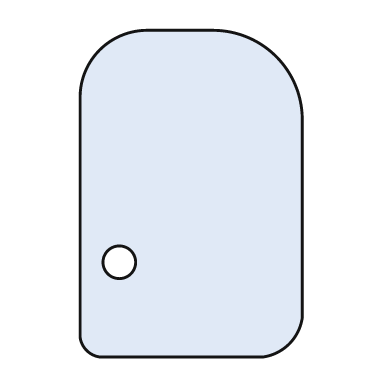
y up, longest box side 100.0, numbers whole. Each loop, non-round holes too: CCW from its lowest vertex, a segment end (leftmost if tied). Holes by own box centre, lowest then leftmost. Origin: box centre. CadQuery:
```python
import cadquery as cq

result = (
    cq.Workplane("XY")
    .moveTo(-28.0, -50.0)
    .lineTo(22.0, -50.0)
    .threePointArc((30.0, -46.0), (34.0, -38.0))
    .lineTo(34.0, 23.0)
    .threePointArc((26.0, 42.0), (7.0, 50.0))
    .lineTo(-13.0, 50.0)
    .threePointArc((-28.0, 44.0), (-34.0, 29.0))
    .lineTo(-34.0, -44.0)
    .threePointArc((-32.0, -48.0), (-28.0, -50.0))
    .close()
    .moveTo(-22.0, -21.0)
    .circle(5.0)
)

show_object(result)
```